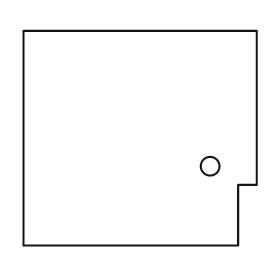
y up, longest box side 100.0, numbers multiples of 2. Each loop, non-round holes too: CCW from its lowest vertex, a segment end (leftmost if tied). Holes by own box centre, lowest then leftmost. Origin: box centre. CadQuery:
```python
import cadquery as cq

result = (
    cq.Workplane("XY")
    .moveTo(-50.0, -46.0)
    .lineTo(42.0, -46.0)
    .lineTo(42.0, -20.0)
    .lineTo(50.0, -20.0)
    .lineTo(50.0, 46.0)
    .lineTo(-50.0, 46.0)
    .close()
    .moveTo(30.0, -12.0)
    .circle(4.0)
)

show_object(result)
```